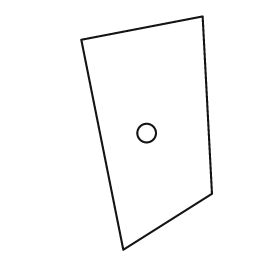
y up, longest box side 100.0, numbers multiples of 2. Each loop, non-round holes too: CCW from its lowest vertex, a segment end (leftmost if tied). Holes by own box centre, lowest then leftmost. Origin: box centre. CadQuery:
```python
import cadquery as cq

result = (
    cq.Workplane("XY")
    .moveTo(-10.0, -50.0)
    .lineTo(28.0, -26.0)
    .lineTo(24.0, 50.0)
    .lineTo(-28.0, 40.0)
    .close()
    .moveTo(0.0, 0.0)
    .circle(4.0)
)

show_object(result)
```